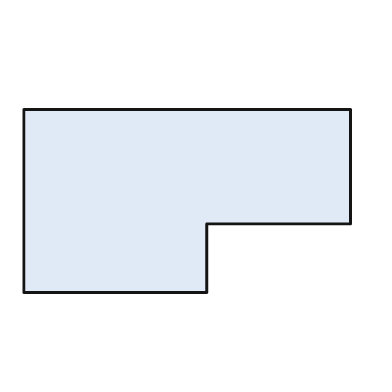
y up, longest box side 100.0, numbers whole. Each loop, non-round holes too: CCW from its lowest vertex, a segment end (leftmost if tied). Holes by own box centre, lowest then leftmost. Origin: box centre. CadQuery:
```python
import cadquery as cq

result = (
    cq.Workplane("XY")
    .moveTo(-50.0, -28.0)
    .lineTo(6.0, -28.0)
    .lineTo(6.0, -7.0)
    .lineTo(50.0, -7.0)
    .lineTo(50.0, 28.0)
    .lineTo(-50.0, 28.0)
    .close()
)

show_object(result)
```